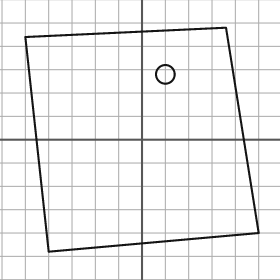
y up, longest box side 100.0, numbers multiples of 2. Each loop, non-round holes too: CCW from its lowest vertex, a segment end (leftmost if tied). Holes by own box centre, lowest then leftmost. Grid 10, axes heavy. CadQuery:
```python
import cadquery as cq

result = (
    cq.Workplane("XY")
    .moveTo(-40.0, -48.0)
    .lineTo(50.0, -40.0)
    .lineTo(36.0, 48.0)
    .lineTo(-50.0, 44.0)
    .close()
    .moveTo(10.0, 28.0)
    .circle(4.0)
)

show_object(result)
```